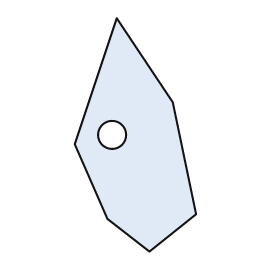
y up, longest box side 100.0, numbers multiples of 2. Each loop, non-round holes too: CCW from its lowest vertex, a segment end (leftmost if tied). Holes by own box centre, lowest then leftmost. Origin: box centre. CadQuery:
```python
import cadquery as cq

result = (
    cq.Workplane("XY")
    .moveTo(6.0, -50.0)
    .lineTo(26.0, -34.0)
    .lineTo(16.0, 14.0)
    .lineTo(-8.0, 50.0)
    .lineTo(-26.0, -4.0)
    .lineTo(-12.0, -36.0)
    .close()
    .moveTo(-10.0, 0.0)
    .circle(6.0)
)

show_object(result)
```